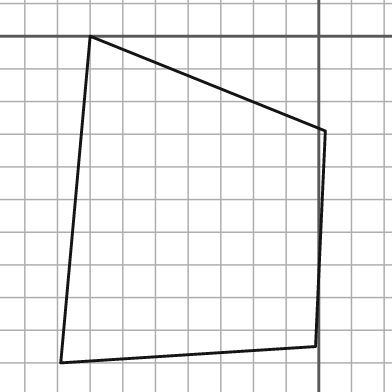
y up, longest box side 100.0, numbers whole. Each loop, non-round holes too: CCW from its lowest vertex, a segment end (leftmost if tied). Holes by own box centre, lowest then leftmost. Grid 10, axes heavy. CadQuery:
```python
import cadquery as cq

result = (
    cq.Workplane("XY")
    .moveTo(-79.0, -100.0)
    .lineTo(-1.0, -95.0)
    .lineTo(2.0, -29.0)
    .lineTo(-70.0, 0.0)
    .close()
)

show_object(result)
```